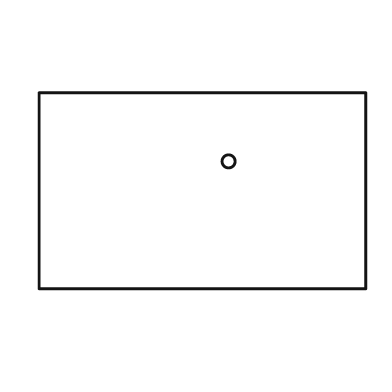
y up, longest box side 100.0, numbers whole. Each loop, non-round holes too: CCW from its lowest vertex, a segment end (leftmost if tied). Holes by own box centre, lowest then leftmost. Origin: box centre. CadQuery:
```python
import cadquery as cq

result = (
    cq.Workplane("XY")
    .moveTo(-50.0, -30.0)
    .lineTo(50.0, -30.0)
    .lineTo(50.0, 30.0)
    .lineTo(-50.0, 30.0)
    .close()
    .moveTo(8.0, 9.0)
    .circle(2.0)
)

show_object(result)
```